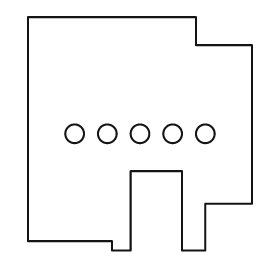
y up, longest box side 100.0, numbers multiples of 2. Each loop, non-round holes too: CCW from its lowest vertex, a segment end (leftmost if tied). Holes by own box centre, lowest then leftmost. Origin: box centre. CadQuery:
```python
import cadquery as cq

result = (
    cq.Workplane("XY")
    .moveTo(-12.0, -50.0)
    .lineTo(-4.0, -50.0)
    .lineTo(-4.0, -16.0)
    .lineTo(18.0, -16.0)
    .lineTo(18.0, -50.0)
    .lineTo(28.0, -50.0)
    .lineTo(28.0, -30.0)
    .lineTo(48.0, -30.0)
    .lineTo(48.0, 38.0)
    .lineTo(24.0, 38.0)
    .lineTo(24.0, 50.0)
    .lineTo(-48.0, 50.0)
    .lineTo(-48.0, -46.0)
    .lineTo(-12.0, -46.0)
    .close()
    .moveTo(-28.0, 0.0)
    .circle(4.0)
    .moveTo(-14.0, 0.0)
    .circle(4.0)
    .moveTo(0.0, 0.0)
    .circle(4.0)
    .moveTo(14.0, 0.0)
    .circle(4.0)
    .moveTo(28.0, 0.0)
    .circle(4.0)
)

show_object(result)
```